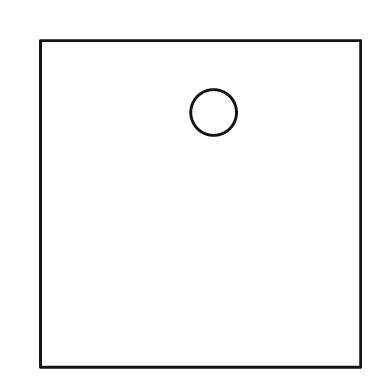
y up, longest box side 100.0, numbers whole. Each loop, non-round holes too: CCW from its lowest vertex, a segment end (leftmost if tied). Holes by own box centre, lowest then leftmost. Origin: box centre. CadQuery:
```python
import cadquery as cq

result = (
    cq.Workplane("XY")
    .moveTo(-49.0, -50.0)
    .lineTo(49.0, -50.0)
    .lineTo(49.0, 50.0)
    .lineTo(-49.0, 50.0)
    .close()
    .moveTo(4.0, 28.0)
    .circle(7.0)
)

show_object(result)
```